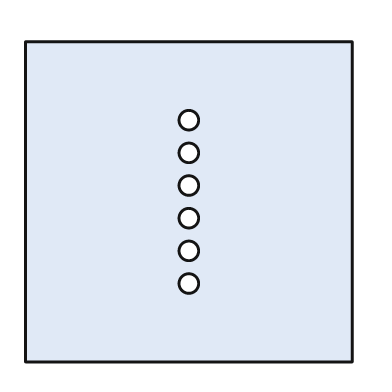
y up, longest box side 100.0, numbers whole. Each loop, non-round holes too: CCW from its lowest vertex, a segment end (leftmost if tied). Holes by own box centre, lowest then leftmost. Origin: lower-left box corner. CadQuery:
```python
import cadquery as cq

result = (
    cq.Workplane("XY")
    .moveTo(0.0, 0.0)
    .lineTo(100.0, 0.0)
    .lineTo(100.0, 98.0)
    .lineTo(0.0, 98.0)
    .close()
    .moveTo(50.0, 24.0)
    .circle(3.0)
    .moveTo(50.0, 34.0)
    .circle(3.0)
    .moveTo(50.0, 44.0)
    .circle(3.0)
    .moveTo(50.0, 54.0)
    .circle(3.0)
    .moveTo(50.0, 64.0)
    .circle(3.0)
    .moveTo(50.0, 74.0)
    .circle(3.0)
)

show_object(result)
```